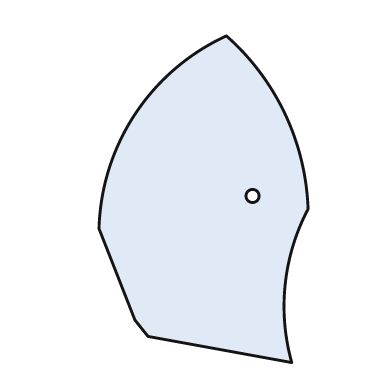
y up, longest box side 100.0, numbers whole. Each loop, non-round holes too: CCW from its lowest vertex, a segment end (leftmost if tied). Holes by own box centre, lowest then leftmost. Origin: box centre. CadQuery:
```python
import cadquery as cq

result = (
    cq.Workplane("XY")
    .moveTo(27.0, -50.0)
    .threePointArc((25.0, -26.0), (32.0, -3.0))
    .threePointArc((25.0, 26.0), (7.0, 50.0))
    .threePointArc((-21.0, 26.0), (-32.0, -9.0))
    .lineTo(-21.0, -37.0)
    .lineTo(-17.0, -42.0)
    .close()
    .moveTo(15.0, 1.0)
    .circle(2.0)
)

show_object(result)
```